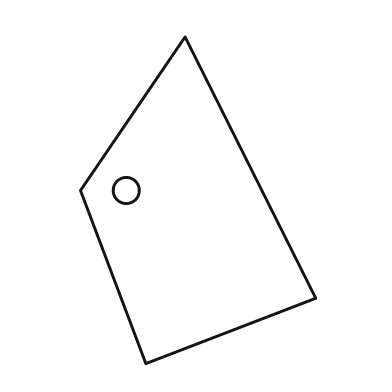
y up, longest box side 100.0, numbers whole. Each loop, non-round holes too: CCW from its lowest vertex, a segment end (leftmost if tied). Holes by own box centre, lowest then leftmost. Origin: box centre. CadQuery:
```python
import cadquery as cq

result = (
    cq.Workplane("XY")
    .moveTo(-16.0, -50.0)
    .lineTo(36.0, -30.0)
    .lineTo(-4.0, 50.0)
    .lineTo(-36.0, 3.0)
    .close()
    .moveTo(-22.0, 3.0)
    .circle(4.0)
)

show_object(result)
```